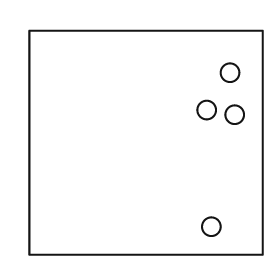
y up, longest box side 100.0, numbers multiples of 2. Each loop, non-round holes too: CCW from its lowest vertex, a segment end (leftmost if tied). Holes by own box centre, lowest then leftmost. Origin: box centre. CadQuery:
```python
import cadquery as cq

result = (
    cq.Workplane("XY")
    .moveTo(-50.0, -48.0)
    .lineTo(50.0, -48.0)
    .lineTo(50.0, 48.0)
    .lineTo(-50.0, 48.0)
    .close()
    .moveTo(28.0, -36.0)
    .circle(4.0)
    .moveTo(38.0, 12.0)
    .circle(4.0)
    .moveTo(26.0, 14.0)
    .circle(4.0)
    .moveTo(36.0, 30.0)
    .circle(4.0)
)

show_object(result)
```